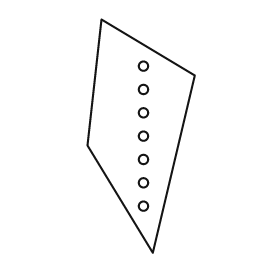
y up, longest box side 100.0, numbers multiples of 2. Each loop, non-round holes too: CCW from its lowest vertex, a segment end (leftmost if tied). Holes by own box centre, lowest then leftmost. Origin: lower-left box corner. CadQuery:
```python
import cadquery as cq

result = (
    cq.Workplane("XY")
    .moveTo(28.0, 0.0)
    .lineTo(46.0, 76.0)
    .lineTo(6.0, 100.0)
    .lineTo(0.0, 46.0)
    .close()
    .moveTo(24.0, 20.0)
    .circle(2.0)
    .moveTo(24.0, 30.0)
    .circle(2.0)
    .moveTo(24.0, 40.0)
    .circle(2.0)
    .moveTo(24.0, 50.0)
    .circle(2.0)
    .moveTo(24.0, 60.0)
    .circle(2.0)
    .moveTo(24.0, 70.0)
    .circle(2.0)
    .moveTo(24.0, 80.0)
    .circle(2.0)
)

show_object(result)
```